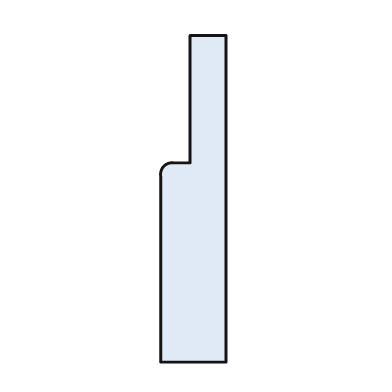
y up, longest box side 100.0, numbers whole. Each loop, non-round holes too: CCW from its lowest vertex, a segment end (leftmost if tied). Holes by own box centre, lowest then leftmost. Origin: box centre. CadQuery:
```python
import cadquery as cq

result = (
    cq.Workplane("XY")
    .moveTo(-10.0, -50.0)
    .lineTo(10.0, -50.0)
    .lineTo(10.0, 50.0)
    .lineTo(-1.0, 50.0)
    .lineTo(-1.0, 11.0)
    .lineTo(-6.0, 11.0)
    .threePointArc((-9.0, 10.0), (-10.0, 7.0))
    .close()
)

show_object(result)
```